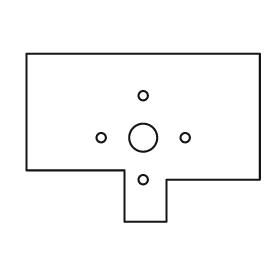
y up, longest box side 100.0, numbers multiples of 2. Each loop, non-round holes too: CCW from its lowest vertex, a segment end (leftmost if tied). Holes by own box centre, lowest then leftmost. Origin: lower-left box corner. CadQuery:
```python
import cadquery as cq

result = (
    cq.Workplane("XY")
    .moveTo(42.0, 0.0)
    .lineTo(60.0, 0.0)
    .lineTo(60.0, 18.0)
    .lineTo(100.0, 18.0)
    .lineTo(100.0, 72.0)
    .lineTo(0.0, 72.0)
    .lineTo(0.0, 22.0)
    .lineTo(42.0, 22.0)
    .close()
    .moveTo(50.0, 18.0)
    .circle(2.0)
    .moveTo(32.0, 36.0)
    .circle(2.0)
    .moveTo(50.0, 36.0)
    .circle(6.0)
    .moveTo(68.0, 36.0)
    .circle(2.0)
    .moveTo(50.0, 54.0)
    .circle(2.0)
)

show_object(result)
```